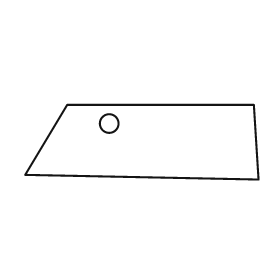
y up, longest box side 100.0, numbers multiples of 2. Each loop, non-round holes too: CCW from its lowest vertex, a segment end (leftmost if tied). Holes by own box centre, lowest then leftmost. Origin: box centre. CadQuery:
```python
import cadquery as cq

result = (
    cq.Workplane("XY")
    .moveTo(50.0, -16.0)
    .lineTo(48.0, 16.0)
    .lineTo(-32.0, 16.0)
    .lineTo(-50.0, -14.0)
    .close()
    .moveTo(-14.0, 8.0)
    .circle(4.0)
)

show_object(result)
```